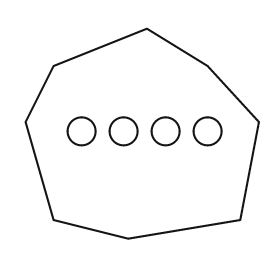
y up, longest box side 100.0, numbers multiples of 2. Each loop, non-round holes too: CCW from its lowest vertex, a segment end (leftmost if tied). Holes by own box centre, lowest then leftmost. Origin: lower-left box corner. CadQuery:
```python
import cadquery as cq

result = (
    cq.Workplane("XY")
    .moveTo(44.0, 0.0)
    .lineTo(92.0, 8.0)
    .lineTo(100.0, 50.0)
    .lineTo(78.0, 74.0)
    .lineTo(52.0, 90.0)
    .lineTo(12.0, 74.0)
    .lineTo(0.0, 50.0)
    .lineTo(12.0, 8.0)
    .close()
    .moveTo(24.0, 46.0)
    .circle(6.0)
    .moveTo(42.0, 46.0)
    .circle(6.0)
    .moveTo(60.0, 46.0)
    .circle(6.0)
    .moveTo(78.0, 46.0)
    .circle(6.0)
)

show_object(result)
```